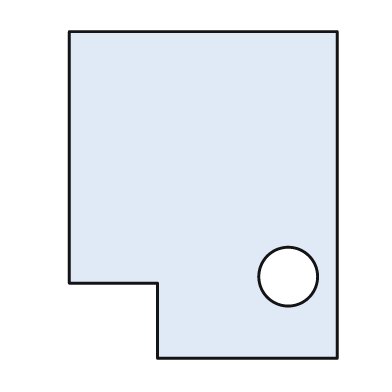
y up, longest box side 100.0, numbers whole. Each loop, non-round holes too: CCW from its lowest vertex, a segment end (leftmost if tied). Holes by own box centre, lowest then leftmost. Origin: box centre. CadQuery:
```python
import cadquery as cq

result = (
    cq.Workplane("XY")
    .moveTo(-14.0, -50.0)
    .lineTo(41.0, -50.0)
    .lineTo(41.0, 50.0)
    .lineTo(-41.0, 50.0)
    .lineTo(-41.0, -27.0)
    .lineTo(-14.0, -27.0)
    .close()
    .moveTo(26.0, -25.0)
    .circle(9.0)
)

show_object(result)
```